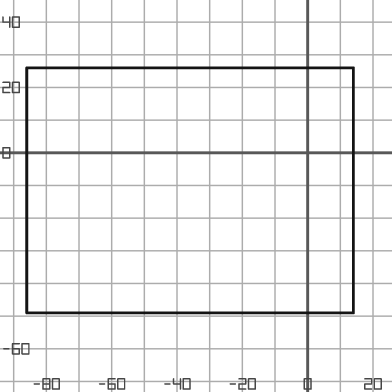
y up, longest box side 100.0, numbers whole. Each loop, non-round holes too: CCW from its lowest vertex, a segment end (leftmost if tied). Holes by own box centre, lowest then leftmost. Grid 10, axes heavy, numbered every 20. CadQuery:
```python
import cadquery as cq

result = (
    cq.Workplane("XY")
    .moveTo(-86.0, -49.0)
    .lineTo(14.0, -49.0)
    .lineTo(14.0, 26.0)
    .lineTo(-86.0, 26.0)
    .close()
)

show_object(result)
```